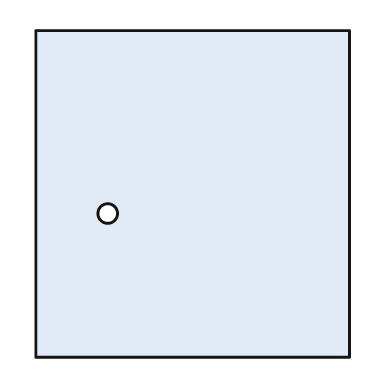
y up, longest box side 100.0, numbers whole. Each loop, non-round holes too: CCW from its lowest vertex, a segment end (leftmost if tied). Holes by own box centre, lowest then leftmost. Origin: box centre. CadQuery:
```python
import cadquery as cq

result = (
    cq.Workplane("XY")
    .moveTo(-48.0, -50.0)
    .lineTo(48.0, -50.0)
    .lineTo(48.0, 50.0)
    .lineTo(-48.0, 50.0)
    .close()
    .moveTo(-26.0, -6.0)
    .circle(3.0)
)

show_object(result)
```